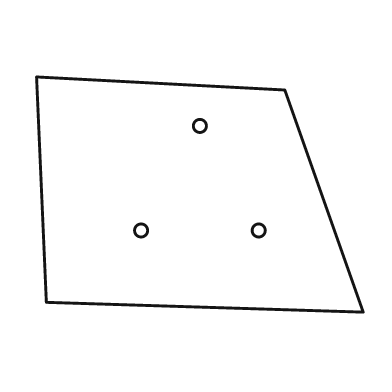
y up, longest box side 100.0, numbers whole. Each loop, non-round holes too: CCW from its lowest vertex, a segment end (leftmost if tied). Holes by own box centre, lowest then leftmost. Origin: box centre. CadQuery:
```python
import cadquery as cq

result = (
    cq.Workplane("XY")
    .moveTo(50.0, -36.0)
    .lineTo(26.0, 32.0)
    .lineTo(-50.0, 36.0)
    .lineTo(-47.0, -33.0)
    .close()
    .moveTo(-18.0, -11.0)
    .circle(2.0)
    .moveTo(18.0, -11.0)
    .circle(2.0)
    .moveTo(0.0, 21.0)
    .circle(2.0)
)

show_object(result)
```